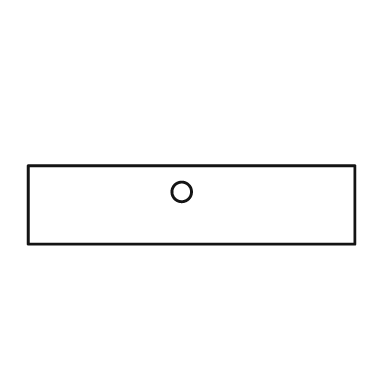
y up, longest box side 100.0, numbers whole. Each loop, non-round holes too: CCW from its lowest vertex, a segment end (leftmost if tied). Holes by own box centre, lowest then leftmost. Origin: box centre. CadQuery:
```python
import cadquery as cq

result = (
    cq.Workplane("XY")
    .moveTo(-50.0, -12.0)
    .lineTo(50.0, -12.0)
    .lineTo(50.0, 12.0)
    .lineTo(-50.0, 12.0)
    .close()
    .moveTo(-3.0, 4.0)
    .circle(3.0)
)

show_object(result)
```